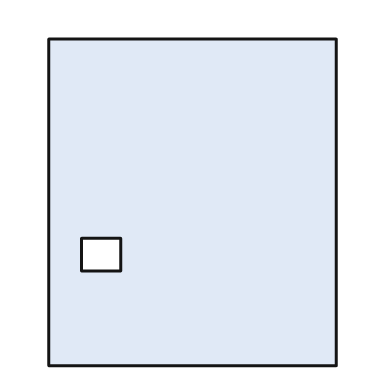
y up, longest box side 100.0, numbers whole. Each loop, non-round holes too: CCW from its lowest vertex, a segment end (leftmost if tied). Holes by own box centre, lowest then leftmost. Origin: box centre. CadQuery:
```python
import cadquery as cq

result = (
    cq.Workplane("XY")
    .moveTo(-44.0, -50.0)
    .lineTo(44.0, -50.0)
    .lineTo(44.0, 50.0)
    .lineTo(-44.0, 50.0)
    .close()
    .moveTo(-34.0, -21.0)
    .lineTo(-22.0, -21.0)
    .lineTo(-22.0, -11.0)
    .lineTo(-34.0, -11.0)
    .close()
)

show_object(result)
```